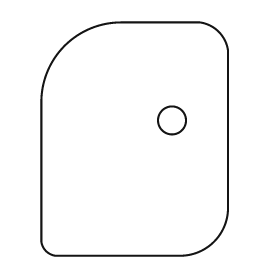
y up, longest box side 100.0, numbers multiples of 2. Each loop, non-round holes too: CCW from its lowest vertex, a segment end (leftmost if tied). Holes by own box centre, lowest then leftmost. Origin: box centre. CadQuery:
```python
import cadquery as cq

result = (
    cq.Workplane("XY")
    .moveTo(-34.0, -50.0)
    .lineTo(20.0, -50.0)
    .threePointArc((34.0, -44.0), (40.0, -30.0))
    .lineTo(40.0, 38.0)
    .threePointArc((36.0, 46.0), (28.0, 50.0))
    .lineTo(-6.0, 50.0)
    .threePointArc((-30.0, 40.0), (-40.0, 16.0))
    .lineTo(-40.0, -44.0)
    .threePointArc((-38.0, -48.0), (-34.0, -50.0))
    .close()
    .moveTo(16.0, 8.0)
    .circle(6.0)
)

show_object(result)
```